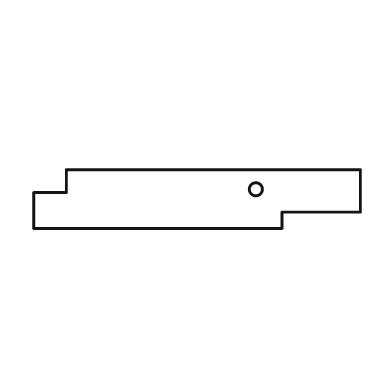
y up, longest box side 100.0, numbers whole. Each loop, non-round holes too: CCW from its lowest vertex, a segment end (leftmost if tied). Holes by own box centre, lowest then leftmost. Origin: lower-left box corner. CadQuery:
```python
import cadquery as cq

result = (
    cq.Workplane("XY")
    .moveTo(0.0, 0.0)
    .lineTo(76.0, 0.0)
    .lineTo(76.0, 5.0)
    .lineTo(100.0, 5.0)
    .lineTo(100.0, 18.0)
    .lineTo(10.0, 18.0)
    .lineTo(10.0, 11.0)
    .lineTo(0.0, 11.0)
    .close()
    .moveTo(68.0, 12.0)
    .circle(2.0)
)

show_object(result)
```